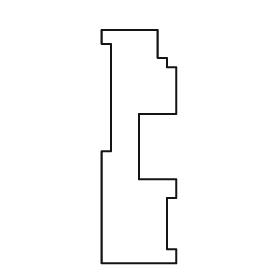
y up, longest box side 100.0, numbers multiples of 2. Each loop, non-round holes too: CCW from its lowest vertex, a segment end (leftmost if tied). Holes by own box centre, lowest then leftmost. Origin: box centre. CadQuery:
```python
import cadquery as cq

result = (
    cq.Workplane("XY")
    .moveTo(-16.0, -50.0)
    .lineTo(16.0, -50.0)
    .lineTo(16.0, -44.0)
    .lineTo(12.0, -44.0)
    .lineTo(12.0, -22.0)
    .lineTo(16.0, -22.0)
    .lineTo(16.0, -14.0)
    .lineTo(0.0, -14.0)
    .lineTo(0.0, 14.0)
    .lineTo(16.0, 14.0)
    .lineTo(16.0, 34.0)
    .lineTo(12.0, 34.0)
    .lineTo(12.0, 38.0)
    .lineTo(8.0, 38.0)
    .lineTo(8.0, 50.0)
    .lineTo(-16.0, 50.0)
    .lineTo(-16.0, 44.0)
    .lineTo(-12.0, 44.0)
    .lineTo(-12.0, -2.0)
    .lineTo(-16.0, -2.0)
    .close()
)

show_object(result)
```